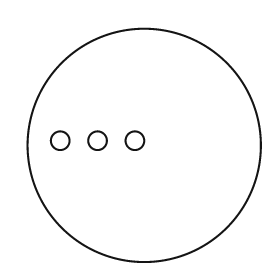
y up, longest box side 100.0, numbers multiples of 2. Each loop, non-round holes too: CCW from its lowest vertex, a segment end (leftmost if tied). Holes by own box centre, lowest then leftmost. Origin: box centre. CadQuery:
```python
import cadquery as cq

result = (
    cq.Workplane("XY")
    .moveTo(0.0, 0.0)
    .circle(50.0)
    .moveTo(-36.0, 2.0)
    .circle(4.0)
    .moveTo(-20.0, 2.0)
    .circle(4.0)
    .moveTo(-4.0, 2.0)
    .circle(4.0)
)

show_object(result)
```